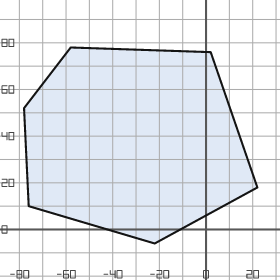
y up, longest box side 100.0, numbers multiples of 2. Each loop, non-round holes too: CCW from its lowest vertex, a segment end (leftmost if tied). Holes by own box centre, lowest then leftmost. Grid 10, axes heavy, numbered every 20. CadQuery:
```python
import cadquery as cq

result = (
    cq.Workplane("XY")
    .moveTo(-22.0, -6.0)
    .lineTo(22.0, 18.0)
    .lineTo(2.0, 76.0)
    .lineTo(-58.0, 78.0)
    .lineTo(-78.0, 52.0)
    .lineTo(-76.0, 10.0)
    .close()
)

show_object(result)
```